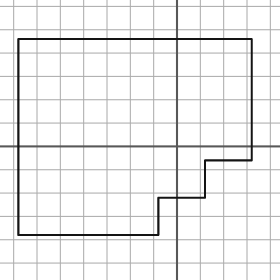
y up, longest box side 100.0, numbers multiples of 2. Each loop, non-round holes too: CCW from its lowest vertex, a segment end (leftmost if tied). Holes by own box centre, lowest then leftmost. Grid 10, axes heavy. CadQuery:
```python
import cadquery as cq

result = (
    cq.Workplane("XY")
    .moveTo(-68.0, -38.0)
    .lineTo(-8.0, -38.0)
    .lineTo(-8.0, -22.0)
    .lineTo(12.0, -22.0)
    .lineTo(12.0, -6.0)
    .lineTo(32.0, -6.0)
    .lineTo(32.0, 46.0)
    .lineTo(-68.0, 46.0)
    .close()
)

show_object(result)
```